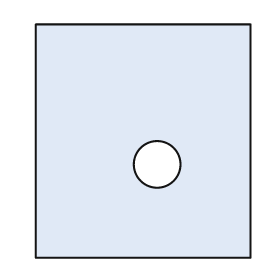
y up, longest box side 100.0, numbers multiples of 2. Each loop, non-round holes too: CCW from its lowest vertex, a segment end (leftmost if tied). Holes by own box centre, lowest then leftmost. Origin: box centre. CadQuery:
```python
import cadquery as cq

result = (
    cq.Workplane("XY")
    .moveTo(-46.0, -50.0)
    .lineTo(46.0, -50.0)
    .lineTo(46.0, 50.0)
    .lineTo(-46.0, 50.0)
    .close()
    .moveTo(6.0, -10.0)
    .circle(10.0)
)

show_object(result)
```